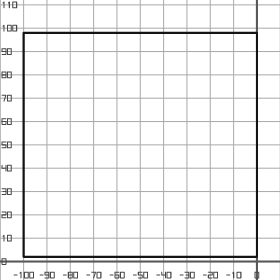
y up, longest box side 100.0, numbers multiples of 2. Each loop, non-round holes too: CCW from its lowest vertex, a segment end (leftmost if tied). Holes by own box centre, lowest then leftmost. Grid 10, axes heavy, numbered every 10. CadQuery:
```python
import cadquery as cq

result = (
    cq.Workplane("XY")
    .moveTo(-100.0, 2.0)
    .lineTo(0.0, 2.0)
    .lineTo(0.0, 98.0)
    .lineTo(-100.0, 98.0)
    .close()
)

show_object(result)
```